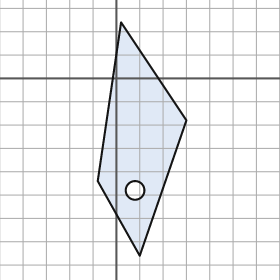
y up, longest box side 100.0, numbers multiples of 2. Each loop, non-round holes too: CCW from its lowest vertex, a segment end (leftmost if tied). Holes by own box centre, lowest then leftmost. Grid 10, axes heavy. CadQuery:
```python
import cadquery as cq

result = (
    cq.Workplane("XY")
    .moveTo(10.0, -76.0)
    .lineTo(30.0, -18.0)
    .lineTo(2.0, 24.0)
    .lineTo(-8.0, -44.0)
    .close()
    .moveTo(8.0, -48.0)
    .circle(4.0)
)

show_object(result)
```